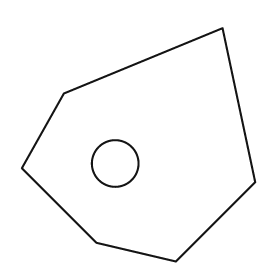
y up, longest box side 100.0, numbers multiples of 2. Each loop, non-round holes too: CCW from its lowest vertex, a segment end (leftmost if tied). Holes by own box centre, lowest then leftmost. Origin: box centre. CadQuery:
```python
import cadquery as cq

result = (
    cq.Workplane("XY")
    .moveTo(16.0, -50.0)
    .lineTo(50.0, -16.0)
    .lineTo(36.0, 50.0)
    .lineTo(-32.0, 22.0)
    .lineTo(-50.0, -10.0)
    .lineTo(-18.0, -42.0)
    .close()
    .moveTo(-10.0, -8.0)
    .circle(10.0)
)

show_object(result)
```